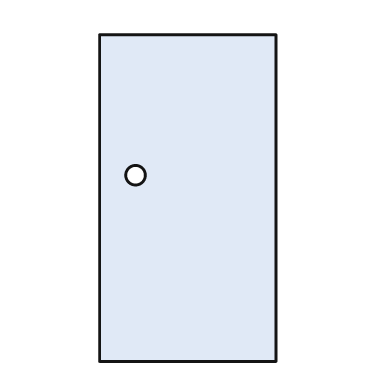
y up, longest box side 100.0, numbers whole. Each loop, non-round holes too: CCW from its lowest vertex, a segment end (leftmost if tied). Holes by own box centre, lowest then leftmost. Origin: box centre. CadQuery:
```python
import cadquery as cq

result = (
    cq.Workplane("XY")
    .moveTo(-27.0, -50.0)
    .lineTo(27.0, -50.0)
    .lineTo(27.0, 50.0)
    .lineTo(-27.0, 50.0)
    .close()
    .moveTo(-16.0, 7.0)
    .circle(3.0)
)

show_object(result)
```